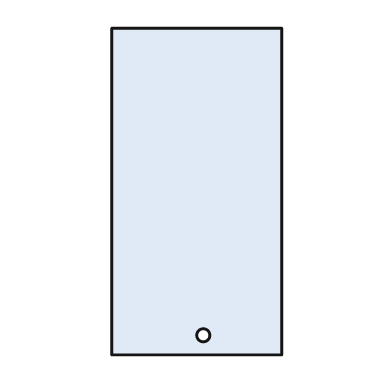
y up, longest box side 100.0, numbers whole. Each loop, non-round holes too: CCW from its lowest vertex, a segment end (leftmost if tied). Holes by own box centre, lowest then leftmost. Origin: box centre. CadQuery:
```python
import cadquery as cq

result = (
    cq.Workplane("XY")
    .moveTo(-26.0, -50.0)
    .lineTo(26.0, -50.0)
    .lineTo(26.0, 50.0)
    .lineTo(-26.0, 50.0)
    .close()
    .moveTo(2.0, -44.0)
    .circle(2.0)
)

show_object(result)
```